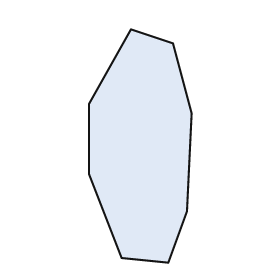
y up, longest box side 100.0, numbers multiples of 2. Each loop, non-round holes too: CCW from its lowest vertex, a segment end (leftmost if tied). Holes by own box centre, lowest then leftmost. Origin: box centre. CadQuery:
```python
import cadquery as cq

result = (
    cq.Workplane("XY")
    .moveTo(12.0, -50.0)
    .lineTo(20.0, -28.0)
    .lineTo(22.0, 14.0)
    .lineTo(14.0, 44.0)
    .lineTo(-4.0, 50.0)
    .lineTo(-22.0, 18.0)
    .lineTo(-22.0, -12.0)
    .lineTo(-8.0, -48.0)
    .close()
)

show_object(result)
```